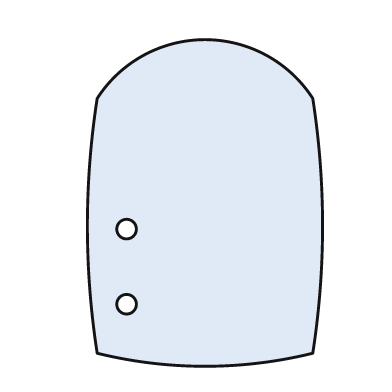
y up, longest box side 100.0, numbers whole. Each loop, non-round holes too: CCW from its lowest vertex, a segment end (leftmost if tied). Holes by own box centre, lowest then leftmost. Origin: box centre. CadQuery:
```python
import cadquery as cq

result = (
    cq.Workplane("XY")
    .moveTo(-33.0, -46.0)
    .threePointArc((0.0, -50.0), (33.0, -46.0))
    .threePointArc((36.0, -7.0), (33.0, 32.0))
    .threePointArc((0.0, 50.0), (-33.0, 32.0))
    .threePointArc((-36.0, -7.0), (-33.0, -46.0))
    .close()
    .moveTo(-24.0, -31.0)
    .circle(3.0)
    .moveTo(-24.0, -8.0)
    .circle(3.0)
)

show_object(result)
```